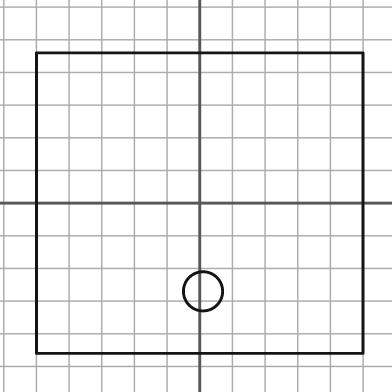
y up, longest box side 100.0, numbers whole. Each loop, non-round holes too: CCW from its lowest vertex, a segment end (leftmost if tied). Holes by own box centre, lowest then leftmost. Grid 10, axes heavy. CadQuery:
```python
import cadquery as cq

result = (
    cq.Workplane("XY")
    .moveTo(-50.0, -46.0)
    .lineTo(50.0, -46.0)
    .lineTo(50.0, 46.0)
    .lineTo(-50.0, 46.0)
    .close()
    .moveTo(1.0, -27.0)
    .circle(6.0)
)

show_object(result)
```